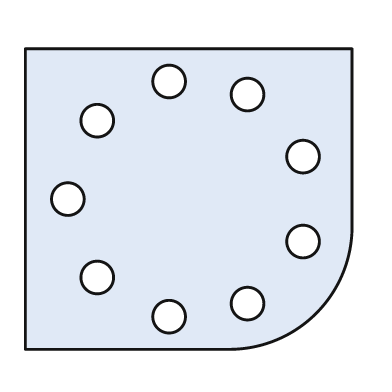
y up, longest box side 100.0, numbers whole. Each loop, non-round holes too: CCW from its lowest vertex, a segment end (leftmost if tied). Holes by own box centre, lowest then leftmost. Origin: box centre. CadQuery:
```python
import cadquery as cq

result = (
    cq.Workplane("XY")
    .moveTo(-50.0, -46.0)
    .lineTo(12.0, -46.0)
    .threePointArc((39.0, -35.0), (50.0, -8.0))
    .lineTo(50.0, 46.0)
    .lineTo(-50.0, 46.0)
    .close()
    .moveTo(-6.0, -36.0)
    .circle(5.0)
    .moveTo(18.0, -32.0)
    .circle(5.0)
    .moveTo(-28.0, -24.0)
    .circle(5.0)
    .moveTo(35.0, -13.0)
    .circle(5.0)
    .moveTo(-37.0, 0.0)
    .circle(5.0)
    .moveTo(35.0, 13.0)
    .circle(5.0)
    .moveTo(-28.0, 24.0)
    .circle(5.0)
    .moveTo(18.0, 32.0)
    .circle(5.0)
    .moveTo(-6.0, 36.0)
    .circle(5.0)
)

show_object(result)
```